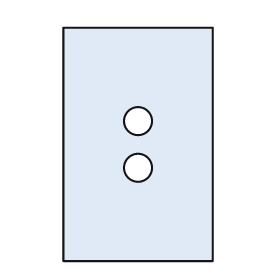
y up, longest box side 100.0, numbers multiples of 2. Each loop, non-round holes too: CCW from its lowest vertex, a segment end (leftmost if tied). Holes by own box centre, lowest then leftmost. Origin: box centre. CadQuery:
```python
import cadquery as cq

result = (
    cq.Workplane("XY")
    .moveTo(-32.0, -50.0)
    .lineTo(32.0, -50.0)
    .lineTo(32.0, 50.0)
    .lineTo(-32.0, 50.0)
    .close()
    .moveTo(0.0, -10.0)
    .circle(6.0)
    .moveTo(0.0, 10.0)
    .circle(6.0)
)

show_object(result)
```